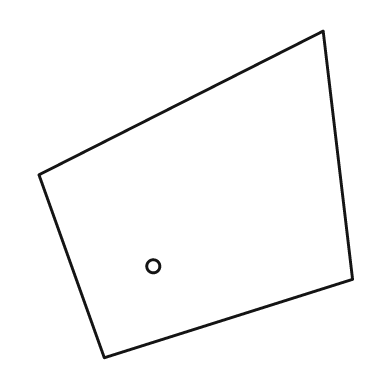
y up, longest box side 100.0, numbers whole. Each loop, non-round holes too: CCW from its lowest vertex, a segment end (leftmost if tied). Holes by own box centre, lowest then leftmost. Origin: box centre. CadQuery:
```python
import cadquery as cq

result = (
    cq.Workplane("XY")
    .moveTo(-28.0, -50.0)
    .lineTo(48.0, -26.0)
    .lineTo(39.0, 50.0)
    .lineTo(-48.0, 6.0)
    .close()
    .moveTo(-13.0, -22.0)
    .circle(2.0)
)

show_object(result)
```